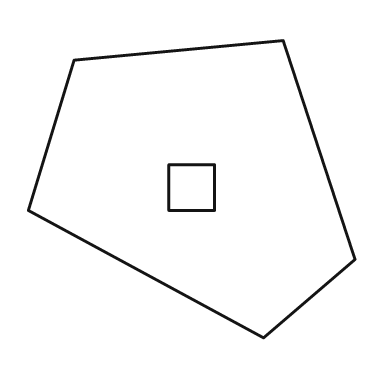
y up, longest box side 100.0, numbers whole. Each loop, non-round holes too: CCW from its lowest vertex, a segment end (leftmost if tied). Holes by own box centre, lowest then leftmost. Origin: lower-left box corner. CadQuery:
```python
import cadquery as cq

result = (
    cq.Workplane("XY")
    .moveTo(72.0, 0.0)
    .lineTo(100.0, 24.0)
    .lineTo(78.0, 91.0)
    .lineTo(14.0, 85.0)
    .lineTo(0.0, 39.0)
    .close()
    .moveTo(43.0, 39.0)
    .lineTo(57.0, 39.0)
    .lineTo(57.0, 53.0)
    .lineTo(43.0, 53.0)
    .close()
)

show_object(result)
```